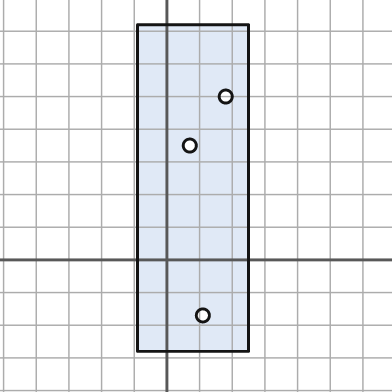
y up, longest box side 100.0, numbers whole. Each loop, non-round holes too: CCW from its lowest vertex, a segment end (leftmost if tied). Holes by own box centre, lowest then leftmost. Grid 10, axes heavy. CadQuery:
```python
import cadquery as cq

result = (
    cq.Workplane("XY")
    .moveTo(-9.0, -28.0)
    .lineTo(25.0, -28.0)
    .lineTo(25.0, 72.0)
    .lineTo(-9.0, 72.0)
    .close()
    .moveTo(11.0, -17.0)
    .circle(2.0)
    .moveTo(7.0, 35.0)
    .circle(2.0)
    .moveTo(18.0, 50.0)
    .circle(2.0)
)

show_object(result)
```